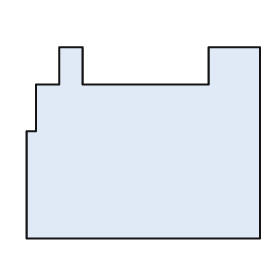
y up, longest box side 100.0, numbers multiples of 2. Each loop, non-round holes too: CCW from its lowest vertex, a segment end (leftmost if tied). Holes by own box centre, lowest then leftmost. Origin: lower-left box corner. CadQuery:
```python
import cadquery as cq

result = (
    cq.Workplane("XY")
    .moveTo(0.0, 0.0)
    .lineTo(100.0, 0.0)
    .lineTo(100.0, 82.0)
    .lineTo(78.0, 82.0)
    .lineTo(78.0, 66.0)
    .lineTo(24.0, 66.0)
    .lineTo(24.0, 82.0)
    .lineTo(14.0, 82.0)
    .lineTo(14.0, 66.0)
    .lineTo(4.0, 66.0)
    .lineTo(4.0, 46.0)
    .lineTo(0.0, 46.0)
    .close()
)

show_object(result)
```